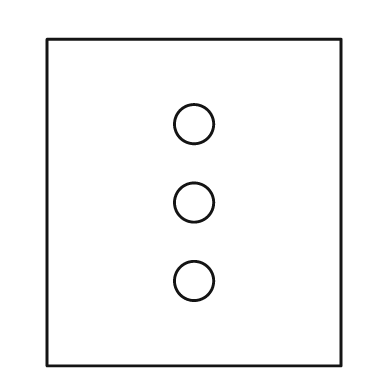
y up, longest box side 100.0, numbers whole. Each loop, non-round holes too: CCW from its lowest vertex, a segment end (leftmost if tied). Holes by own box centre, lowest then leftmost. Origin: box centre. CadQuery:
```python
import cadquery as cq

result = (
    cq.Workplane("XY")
    .moveTo(-45.0, -50.0)
    .lineTo(45.0, -50.0)
    .lineTo(45.0, 50.0)
    .lineTo(-45.0, 50.0)
    .close()
    .moveTo(0.0, -24.0)
    .circle(6.0)
    .moveTo(0.0, 0.0)
    .circle(6.0)
    .moveTo(0.0, 24.0)
    .circle(6.0)
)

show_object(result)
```